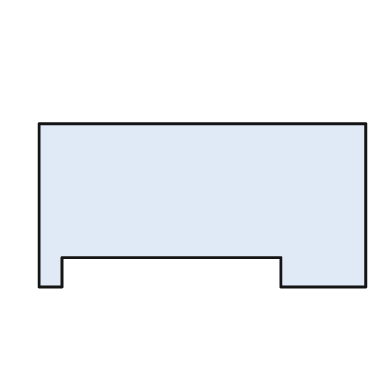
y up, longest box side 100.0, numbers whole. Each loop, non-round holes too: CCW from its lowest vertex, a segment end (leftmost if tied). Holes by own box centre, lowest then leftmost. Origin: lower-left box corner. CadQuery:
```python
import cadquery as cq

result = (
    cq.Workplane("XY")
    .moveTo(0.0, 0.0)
    .lineTo(7.0, 0.0)
    .lineTo(7.0, 9.0)
    .lineTo(74.0, 9.0)
    .lineTo(74.0, 0.0)
    .lineTo(100.0, 0.0)
    .lineTo(100.0, 50.0)
    .lineTo(0.0, 50.0)
    .close()
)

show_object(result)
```